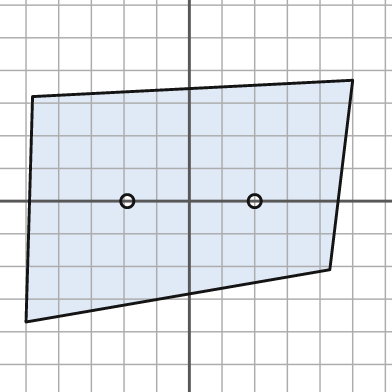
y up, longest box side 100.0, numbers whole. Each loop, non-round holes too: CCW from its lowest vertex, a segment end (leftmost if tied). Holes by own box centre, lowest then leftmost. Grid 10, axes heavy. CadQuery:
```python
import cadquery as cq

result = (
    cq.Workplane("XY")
    .moveTo(-50.0, -37.0)
    .lineTo(43.0, -21.0)
    .lineTo(50.0, 37.0)
    .lineTo(-48.0, 32.0)
    .close()
    .moveTo(-19.0, 0.0)
    .circle(2.0)
    .moveTo(20.0, 0.0)
    .circle(2.0)
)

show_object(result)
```